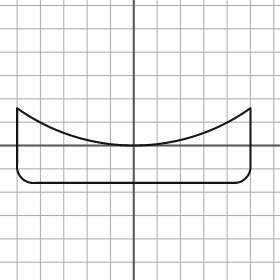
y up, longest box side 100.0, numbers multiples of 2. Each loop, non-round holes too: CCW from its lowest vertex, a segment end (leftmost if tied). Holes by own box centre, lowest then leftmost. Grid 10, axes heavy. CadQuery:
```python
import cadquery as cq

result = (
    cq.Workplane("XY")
    .moveTo(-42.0, -16.0)
    .lineTo(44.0, -16.0)
    .threePointArc((48.0, -14.0), (50.0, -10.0))
    .lineTo(50.0, 16.0)
    .threePointArc((0.0, 0.0), (-50.0, 16.0))
    .lineTo(-50.0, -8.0)
    .threePointArc((-48.0, -14.0), (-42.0, -16.0))
    .close()
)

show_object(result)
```